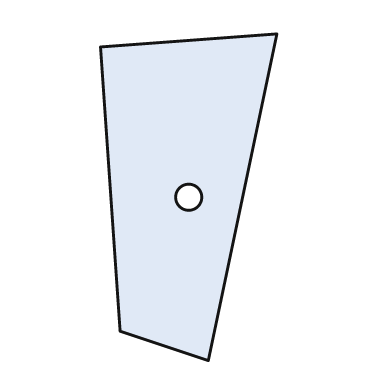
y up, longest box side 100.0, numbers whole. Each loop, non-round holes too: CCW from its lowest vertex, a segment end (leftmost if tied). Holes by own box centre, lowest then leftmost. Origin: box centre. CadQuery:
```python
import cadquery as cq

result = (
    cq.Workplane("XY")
    .moveTo(6.0, -50.0)
    .lineTo(27.0, 50.0)
    .lineTo(-27.0, 46.0)
    .lineTo(-21.0, -41.0)
    .close()
    .moveTo(0.0, 0.0)
    .circle(4.0)
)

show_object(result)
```